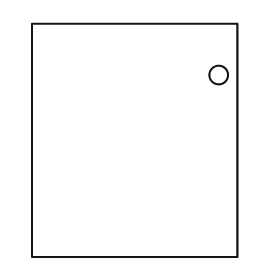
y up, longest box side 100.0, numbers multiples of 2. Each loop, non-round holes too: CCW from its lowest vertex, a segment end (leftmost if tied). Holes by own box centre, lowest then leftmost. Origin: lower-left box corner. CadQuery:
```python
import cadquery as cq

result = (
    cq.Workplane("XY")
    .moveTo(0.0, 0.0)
    .lineTo(88.0, 0.0)
    .lineTo(88.0, 100.0)
    .lineTo(0.0, 100.0)
    .close()
    .moveTo(80.0, 78.0)
    .circle(4.0)
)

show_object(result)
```